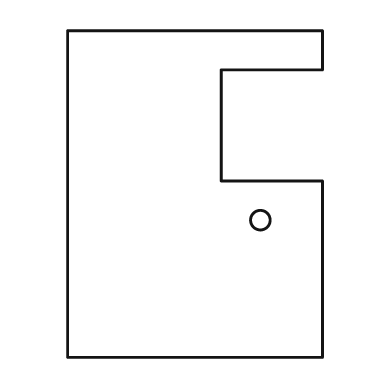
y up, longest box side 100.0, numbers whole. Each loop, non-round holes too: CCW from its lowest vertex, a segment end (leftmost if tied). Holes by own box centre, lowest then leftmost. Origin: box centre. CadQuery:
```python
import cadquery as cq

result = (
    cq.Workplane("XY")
    .moveTo(-39.0, -50.0)
    .lineTo(39.0, -50.0)
    .lineTo(39.0, 4.0)
    .lineTo(8.0, 4.0)
    .lineTo(8.0, 38.0)
    .lineTo(39.0, 38.0)
    .lineTo(39.0, 50.0)
    .lineTo(-39.0, 50.0)
    .close()
    .moveTo(20.0, -8.0)
    .circle(3.0)
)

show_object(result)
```